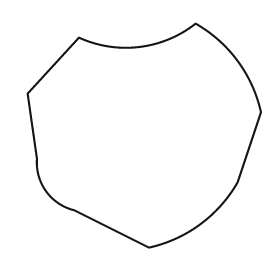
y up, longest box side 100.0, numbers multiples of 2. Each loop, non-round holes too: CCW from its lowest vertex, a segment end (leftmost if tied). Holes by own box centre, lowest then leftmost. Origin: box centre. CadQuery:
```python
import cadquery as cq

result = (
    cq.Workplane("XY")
    .moveTo(2.0, -48.0)
    .threePointArc((24.0, -38.0), (40.0, -20.0))
    .lineTo(50.0, 10.0)
    .threePointArc((40.0, 32.0), (22.0, 48.0))
    .threePointArc((-2.0, 38.0), (-28.0, 42.0))
    .lineTo(-50.0, 18.0)
    .lineTo(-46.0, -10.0)
    .threePointArc((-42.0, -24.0), (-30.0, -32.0))
    .close()
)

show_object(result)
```